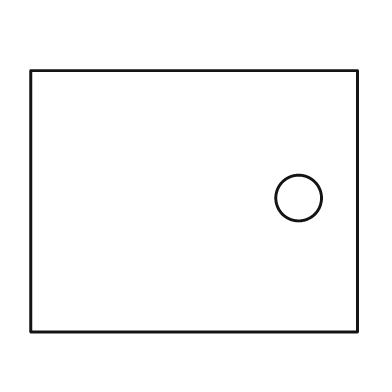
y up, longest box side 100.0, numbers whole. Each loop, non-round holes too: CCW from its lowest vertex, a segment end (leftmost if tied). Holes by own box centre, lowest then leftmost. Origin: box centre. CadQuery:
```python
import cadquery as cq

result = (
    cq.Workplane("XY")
    .moveTo(-50.0, -40.0)
    .lineTo(50.0, -40.0)
    .lineTo(50.0, 40.0)
    .lineTo(-50.0, 40.0)
    .close()
    .moveTo(32.0, 1.0)
    .circle(7.0)
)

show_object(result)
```